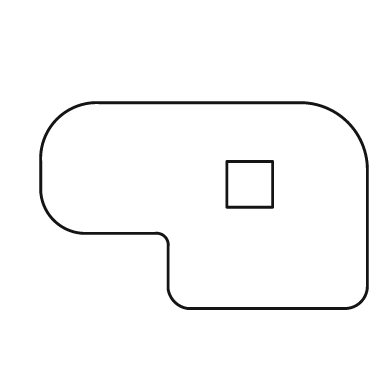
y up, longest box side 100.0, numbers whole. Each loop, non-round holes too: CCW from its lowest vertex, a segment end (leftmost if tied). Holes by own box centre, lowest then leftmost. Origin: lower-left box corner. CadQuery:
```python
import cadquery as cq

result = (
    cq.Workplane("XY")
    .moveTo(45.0, 0.0)
    .lineTo(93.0, 0.0)
    .threePointArc((98.0, 2.0), (100.0, 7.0))
    .lineTo(100.0, 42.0)
    .threePointArc((94.0, 57.0), (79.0, 63.0))
    .lineTo(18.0, 63.0)
    .threePointArc((5.0, 58.0), (0.0, 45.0))
    .lineTo(0.0, 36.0)
    .threePointArc((4.0, 27.0), (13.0, 23.0))
    .lineTo(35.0, 23.0)
    .threePointArc((38.0, 22.0), (39.0, 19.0))
    .lineTo(39.0, 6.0)
    .threePointArc((41.0, 2.0), (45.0, 0.0))
    .close()
    .moveTo(57.0, 31.0)
    .lineTo(71.0, 31.0)
    .lineTo(71.0, 45.0)
    .lineTo(57.0, 45.0)
    .close()
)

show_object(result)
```